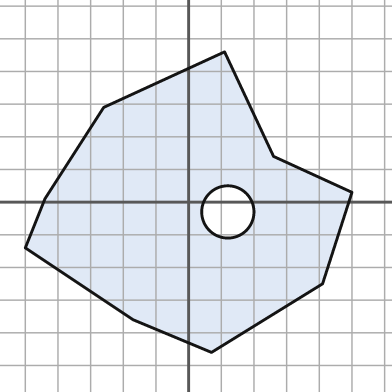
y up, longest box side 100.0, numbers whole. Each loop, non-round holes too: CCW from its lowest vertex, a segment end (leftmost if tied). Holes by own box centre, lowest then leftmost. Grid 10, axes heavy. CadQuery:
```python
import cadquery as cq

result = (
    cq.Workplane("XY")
    .moveTo(7.0, -46.0)
    .lineTo(41.0, -25.0)
    .lineTo(50.0, 3.0)
    .lineTo(26.0, 14.0)
    .lineTo(11.0, 46.0)
    .lineTo(-26.0, 29.0)
    .lineTo(-44.0, 1.0)
    .lineTo(-50.0, -14.0)
    .lineTo(-17.0, -36.0)
    .close()
    .moveTo(12.0, -3.0)
    .circle(8.0)
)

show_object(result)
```